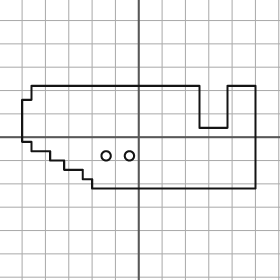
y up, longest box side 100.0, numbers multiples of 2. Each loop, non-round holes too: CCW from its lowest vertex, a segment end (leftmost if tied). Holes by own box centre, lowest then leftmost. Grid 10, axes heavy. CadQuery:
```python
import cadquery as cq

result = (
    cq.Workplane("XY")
    .moveTo(-20.0, -22.0)
    .lineTo(50.0, -22.0)
    .lineTo(50.0, 22.0)
    .lineTo(38.0, 22.0)
    .lineTo(38.0, 4.0)
    .lineTo(26.0, 4.0)
    .lineTo(26.0, 22.0)
    .lineTo(-46.0, 22.0)
    .lineTo(-46.0, 16.0)
    .lineTo(-50.0, 16.0)
    .lineTo(-50.0, -2.0)
    .lineTo(-46.0, -2.0)
    .lineTo(-46.0, -6.0)
    .lineTo(-38.0, -6.0)
    .lineTo(-38.0, -10.0)
    .lineTo(-32.0, -10.0)
    .lineTo(-32.0, -14.0)
    .lineTo(-24.0, -14.0)
    .lineTo(-24.0, -18.0)
    .lineTo(-20.0, -18.0)
    .close()
    .moveTo(-14.0, -8.0)
    .circle(2.0)
    .moveTo(-4.0, -8.0)
    .circle(2.0)
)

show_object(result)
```